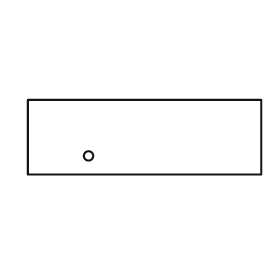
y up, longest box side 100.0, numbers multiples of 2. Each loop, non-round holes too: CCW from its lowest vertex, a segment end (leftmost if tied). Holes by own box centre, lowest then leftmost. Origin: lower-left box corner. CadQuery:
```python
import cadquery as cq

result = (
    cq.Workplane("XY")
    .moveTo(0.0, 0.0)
    .lineTo(100.0, 0.0)
    .lineTo(100.0, 32.0)
    .lineTo(0.0, 32.0)
    .close()
    .moveTo(26.0, 8.0)
    .circle(2.0)
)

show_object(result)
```